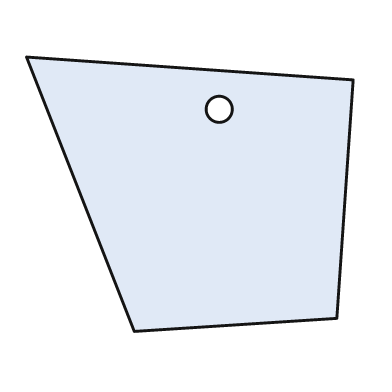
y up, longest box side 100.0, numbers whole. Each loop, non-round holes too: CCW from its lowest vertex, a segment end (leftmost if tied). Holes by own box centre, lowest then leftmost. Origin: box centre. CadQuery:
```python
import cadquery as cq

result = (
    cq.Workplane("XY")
    .moveTo(-17.0, -42.0)
    .lineTo(45.0, -38.0)
    .lineTo(50.0, 35.0)
    .lineTo(-50.0, 42.0)
    .close()
    .moveTo(9.0, 26.0)
    .circle(4.0)
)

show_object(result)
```